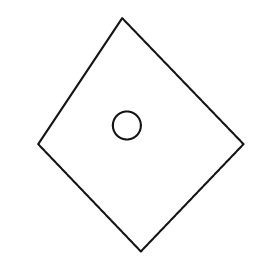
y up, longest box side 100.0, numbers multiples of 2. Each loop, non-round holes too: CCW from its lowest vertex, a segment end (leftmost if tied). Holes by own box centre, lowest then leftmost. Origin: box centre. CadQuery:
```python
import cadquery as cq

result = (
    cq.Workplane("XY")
    .moveTo(0.0, -50.0)
    .lineTo(44.0, -4.0)
    .lineTo(-8.0, 50.0)
    .lineTo(-44.0, -4.0)
    .close()
    .moveTo(-6.0, 4.0)
    .circle(6.0)
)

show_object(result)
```